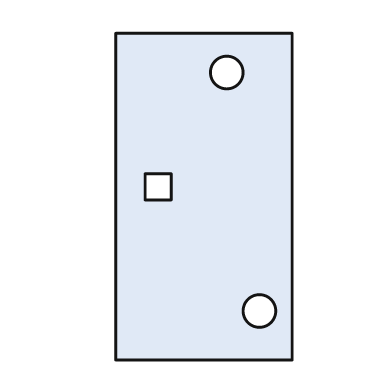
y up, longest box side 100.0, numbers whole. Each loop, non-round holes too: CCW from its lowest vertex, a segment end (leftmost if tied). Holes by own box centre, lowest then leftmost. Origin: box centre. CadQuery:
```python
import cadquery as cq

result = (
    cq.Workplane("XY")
    .moveTo(-27.0, -50.0)
    .lineTo(27.0, -50.0)
    .lineTo(27.0, 50.0)
    .lineTo(-27.0, 50.0)
    .close()
    .moveTo(17.0, -35.0)
    .circle(5.0)
    .moveTo(-18.0, -1.0)
    .lineTo(-10.0, -1.0)
    .lineTo(-10.0, 7.0)
    .lineTo(-18.0, 7.0)
    .close()
    .moveTo(7.0, 38.0)
    .circle(5.0)
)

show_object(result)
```